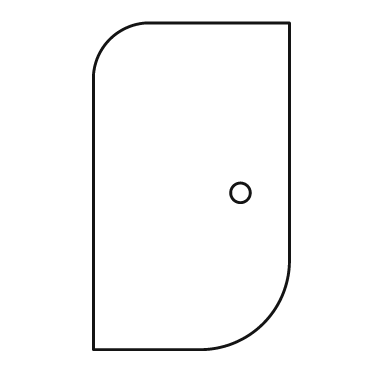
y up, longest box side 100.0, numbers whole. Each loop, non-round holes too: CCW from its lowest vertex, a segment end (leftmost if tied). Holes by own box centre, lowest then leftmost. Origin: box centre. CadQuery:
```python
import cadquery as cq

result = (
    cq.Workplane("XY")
    .moveTo(-30.0, -50.0)
    .lineTo(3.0, -50.0)
    .threePointArc((22.0, -42.0), (30.0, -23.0))
    .lineTo(30.0, 50.0)
    .lineTo(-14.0, 50.0)
    .threePointArc((-25.0, 45.0), (-30.0, 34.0))
    .close()
    .moveTo(15.0, -2.0)
    .circle(3.0)
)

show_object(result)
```